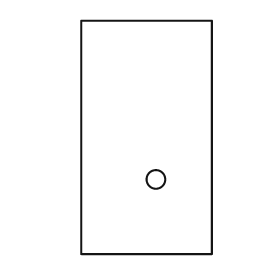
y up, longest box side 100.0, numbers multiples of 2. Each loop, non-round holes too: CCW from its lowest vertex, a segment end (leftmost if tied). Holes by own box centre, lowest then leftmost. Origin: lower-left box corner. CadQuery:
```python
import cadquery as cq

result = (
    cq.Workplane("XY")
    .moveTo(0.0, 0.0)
    .lineTo(56.0, 0.0)
    .lineTo(56.0, 100.0)
    .lineTo(0.0, 100.0)
    .close()
    .moveTo(32.0, 32.0)
    .circle(4.0)
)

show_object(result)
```